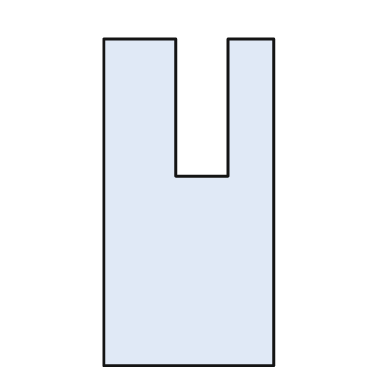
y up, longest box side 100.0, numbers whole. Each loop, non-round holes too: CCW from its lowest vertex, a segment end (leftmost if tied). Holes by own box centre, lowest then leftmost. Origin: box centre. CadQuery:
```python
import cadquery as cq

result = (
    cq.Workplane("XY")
    .moveTo(-26.0, -50.0)
    .lineTo(26.0, -50.0)
    .lineTo(26.0, 50.0)
    .lineTo(12.0, 50.0)
    .lineTo(12.0, 8.0)
    .lineTo(-4.0, 8.0)
    .lineTo(-4.0, 50.0)
    .lineTo(-26.0, 50.0)
    .close()
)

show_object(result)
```